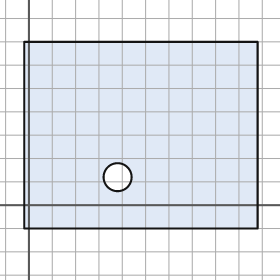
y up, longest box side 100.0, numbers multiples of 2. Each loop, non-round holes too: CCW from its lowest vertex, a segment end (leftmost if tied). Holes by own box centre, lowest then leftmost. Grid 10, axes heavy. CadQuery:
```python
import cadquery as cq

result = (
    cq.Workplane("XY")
    .moveTo(-2.0, -10.0)
    .lineTo(98.0, -10.0)
    .lineTo(98.0, 70.0)
    .lineTo(-2.0, 70.0)
    .close()
    .moveTo(38.0, 12.0)
    .circle(6.0)
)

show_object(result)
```